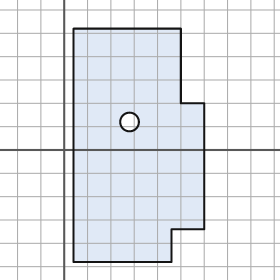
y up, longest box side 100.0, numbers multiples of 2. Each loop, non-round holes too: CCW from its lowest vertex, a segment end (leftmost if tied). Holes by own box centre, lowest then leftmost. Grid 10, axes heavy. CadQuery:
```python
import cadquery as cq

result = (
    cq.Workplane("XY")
    .moveTo(4.0, -48.0)
    .lineTo(46.0, -48.0)
    .lineTo(46.0, -34.0)
    .lineTo(60.0, -34.0)
    .lineTo(60.0, 20.0)
    .lineTo(50.0, 20.0)
    .lineTo(50.0, 52.0)
    .lineTo(4.0, 52.0)
    .close()
    .moveTo(28.0, 12.0)
    .circle(4.0)
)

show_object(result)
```